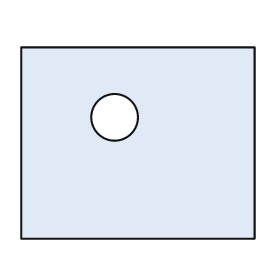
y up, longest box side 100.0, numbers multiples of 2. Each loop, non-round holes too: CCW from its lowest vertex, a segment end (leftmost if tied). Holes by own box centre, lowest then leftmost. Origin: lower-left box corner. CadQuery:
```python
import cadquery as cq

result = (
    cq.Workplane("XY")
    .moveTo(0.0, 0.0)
    .lineTo(100.0, 0.0)
    .lineTo(100.0, 82.0)
    .lineTo(0.0, 82.0)
    .close()
    .moveTo(40.0, 52.0)
    .circle(10.0)
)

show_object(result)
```